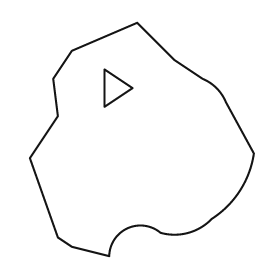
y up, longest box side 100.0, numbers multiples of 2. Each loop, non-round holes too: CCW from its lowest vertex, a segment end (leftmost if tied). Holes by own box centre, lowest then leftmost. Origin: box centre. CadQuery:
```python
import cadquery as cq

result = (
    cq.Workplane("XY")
    .moveTo(-14.0, -50.0)
    .threePointArc((-6.0, -38.0), (8.0, -40.0))
    .threePointArc((20.0, -40.0), (30.0, -34.0))
    .threePointArc((42.0, -22.0), (48.0, -6.0))
    .lineTo(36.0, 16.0)
    .threePointArc((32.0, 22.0), (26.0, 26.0))
    .lineTo(14.0, 34.0)
    .lineTo(-2.0, 50.0)
    .lineTo(-30.0, 38.0)
    .lineTo(-38.0, 26.0)
    .lineTo(-36.0, 10.0)
    .lineTo(-48.0, -8.0)
    .lineTo(-36.0, -42.0)
    .lineTo(-30.0, -46.0)
    .close()
    .moveTo(-16.0, 14.0)
    .lineTo(-4.0, 22.0)
    .lineTo(-16.0, 30.0)
    .close()
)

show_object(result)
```